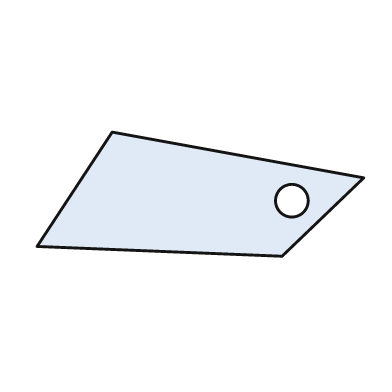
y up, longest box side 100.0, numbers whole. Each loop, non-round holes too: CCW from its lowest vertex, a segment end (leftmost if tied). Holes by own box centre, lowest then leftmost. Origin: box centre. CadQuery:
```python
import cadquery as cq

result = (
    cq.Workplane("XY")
    .moveTo(25.0, -19.0)
    .lineTo(50.0, 5.0)
    .lineTo(-27.0, 19.0)
    .lineTo(-50.0, -16.0)
    .close()
    .moveTo(28.0, -2.0)
    .circle(5.0)
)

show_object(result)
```